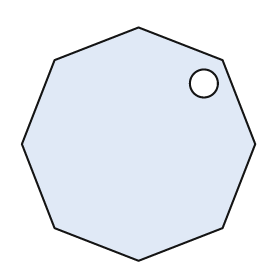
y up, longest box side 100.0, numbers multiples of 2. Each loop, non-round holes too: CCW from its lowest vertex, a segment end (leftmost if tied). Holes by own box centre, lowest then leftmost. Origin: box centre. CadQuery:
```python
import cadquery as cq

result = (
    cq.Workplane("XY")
    .moveTo(0.0, -50.0)
    .lineTo(36.0, -36.0)
    .lineTo(50.0, 0.0)
    .lineTo(36.0, 36.0)
    .lineTo(0.0, 50.0)
    .lineTo(-36.0, 36.0)
    .lineTo(-50.0, 0.0)
    .lineTo(-36.0, -36.0)
    .close()
    .moveTo(28.0, 26.0)
    .circle(6.0)
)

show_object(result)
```